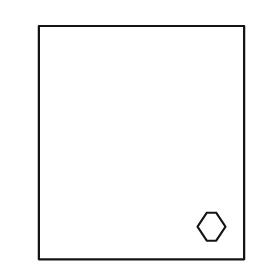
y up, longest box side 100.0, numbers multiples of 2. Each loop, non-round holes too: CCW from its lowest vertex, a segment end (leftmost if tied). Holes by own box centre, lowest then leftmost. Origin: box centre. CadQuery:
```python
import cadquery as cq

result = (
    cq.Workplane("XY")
    .moveTo(-44.0, -50.0)
    .lineTo(44.0, -50.0)
    .lineTo(44.0, 50.0)
    .lineTo(-44.0, 50.0)
    .close()
    .moveTo(28.0, -42.0)
    .lineTo(32.0, -42.0)
    .lineTo(36.0, -36.0)
    .lineTo(32.0, -30.0)
    .lineTo(28.0, -30.0)
    .lineTo(24.0, -36.0)
    .close()
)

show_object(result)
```